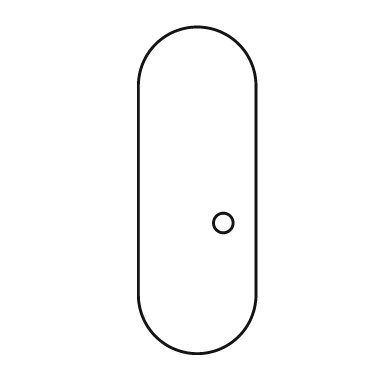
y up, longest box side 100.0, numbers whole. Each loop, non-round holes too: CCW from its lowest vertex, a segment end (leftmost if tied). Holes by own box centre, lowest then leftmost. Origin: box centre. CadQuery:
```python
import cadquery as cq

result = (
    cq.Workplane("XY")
    .moveTo(-18.0, -32.0)
    .threePointArc((0.0, -50.0), (18.0, -32.0))
    .lineTo(18.0, 32.0)
    .threePointArc((0.0, 50.0), (-18.0, 32.0))
    .close()
    .moveTo(8.0, -10.0)
    .circle(3.0)
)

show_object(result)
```